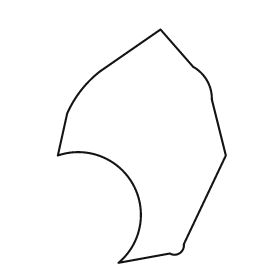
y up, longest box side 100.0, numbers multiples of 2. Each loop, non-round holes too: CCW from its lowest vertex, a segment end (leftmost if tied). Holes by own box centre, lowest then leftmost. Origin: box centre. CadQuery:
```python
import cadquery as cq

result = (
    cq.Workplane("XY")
    .moveTo(-10.0, -50.0)
    .lineTo(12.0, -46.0)
    .threePointArc((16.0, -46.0), (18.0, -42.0))
    .lineTo(36.0, -4.0)
    .lineTo(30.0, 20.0)
    .threePointArc((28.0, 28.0), (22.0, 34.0))
    .lineTo(8.0, 50.0)
    .lineTo(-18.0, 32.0)
    .threePointArc((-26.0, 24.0), (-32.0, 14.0))
    .lineTo(-36.0, -4.0)
    .threePointArc((-4.0, -16.0), (-10.0, -50.0))
    .close()
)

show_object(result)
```